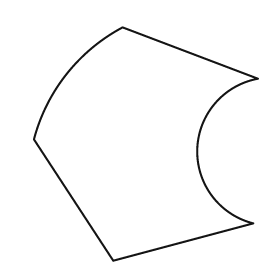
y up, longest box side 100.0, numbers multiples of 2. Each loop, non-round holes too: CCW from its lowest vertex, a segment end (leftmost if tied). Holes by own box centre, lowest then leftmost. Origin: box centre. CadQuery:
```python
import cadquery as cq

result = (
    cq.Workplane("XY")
    .moveTo(-14.0, -50.0)
    .lineTo(46.0, -34.0)
    .threePointArc((22.0, -2.0), (48.0, 28.0))
    .lineTo(-10.0, 50.0)
    .threePointArc((-34.0, 30.0), (-48.0, 2.0))
    .close()
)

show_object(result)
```